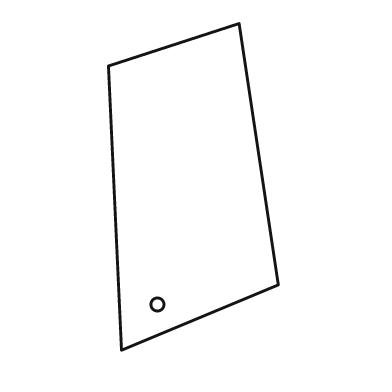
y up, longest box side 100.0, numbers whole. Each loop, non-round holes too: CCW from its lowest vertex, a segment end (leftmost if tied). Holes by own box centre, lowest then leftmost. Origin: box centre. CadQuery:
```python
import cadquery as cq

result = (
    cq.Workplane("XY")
    .moveTo(-22.0, -50.0)
    .lineTo(26.0, -30.0)
    .lineTo(14.0, 50.0)
    .lineTo(-26.0, 37.0)
    .close()
    .moveTo(-11.0, -36.0)
    .circle(2.0)
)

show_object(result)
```